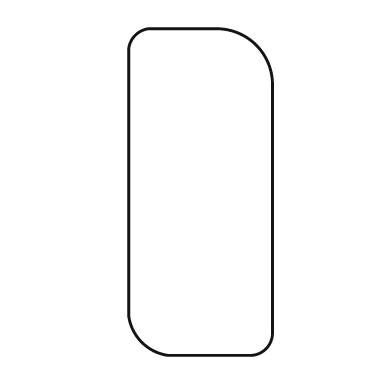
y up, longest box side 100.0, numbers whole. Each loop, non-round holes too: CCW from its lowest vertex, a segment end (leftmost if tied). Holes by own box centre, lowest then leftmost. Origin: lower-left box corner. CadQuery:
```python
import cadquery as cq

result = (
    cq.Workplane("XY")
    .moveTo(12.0, 0.0)
    .lineTo(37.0, 0.0)
    .threePointArc((42.0, 2.0), (44.0, 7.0))
    .lineTo(44.0, 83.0)
    .threePointArc((39.0, 95.0), (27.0, 100.0))
    .lineTo(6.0, 100.0)
    .threePointArc((2.0, 98.0), (0.0, 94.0))
    .lineTo(0.0, 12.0)
    .threePointArc((4.0, 4.0), (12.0, 0.0))
    .close()
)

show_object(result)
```